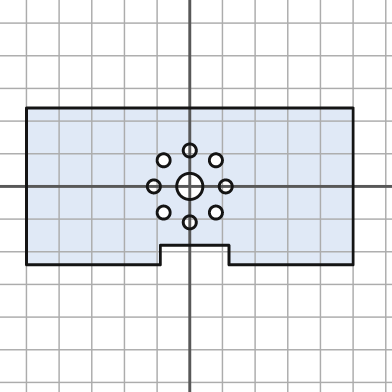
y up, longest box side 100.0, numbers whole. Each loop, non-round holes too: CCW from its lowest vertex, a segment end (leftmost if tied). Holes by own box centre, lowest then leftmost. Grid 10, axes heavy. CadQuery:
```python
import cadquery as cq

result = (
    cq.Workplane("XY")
    .moveTo(-50.0, -24.0)
    .lineTo(-9.0, -24.0)
    .lineTo(-9.0, -18.0)
    .lineTo(12.0, -18.0)
    .lineTo(12.0, -24.0)
    .lineTo(50.0, -24.0)
    .lineTo(50.0, 24.0)
    .lineTo(-50.0, 24.0)
    .close()
    .moveTo(0.0, -11.0)
    .circle(2.0)
    .moveTo(-8.0, -8.0)
    .circle(2.0)
    .moveTo(8.0, -8.0)
    .circle(2.0)
    .moveTo(-11.0, 0.0)
    .circle(2.0)
    .moveTo(0.0, 0.0)
    .circle(4.0)
    .moveTo(11.0, 0.0)
    .circle(2.0)
    .moveTo(-8.0, 8.0)
    .circle(2.0)
    .moveTo(8.0, 8.0)
    .circle(2.0)
    .moveTo(0.0, 11.0)
    .circle(2.0)
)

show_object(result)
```